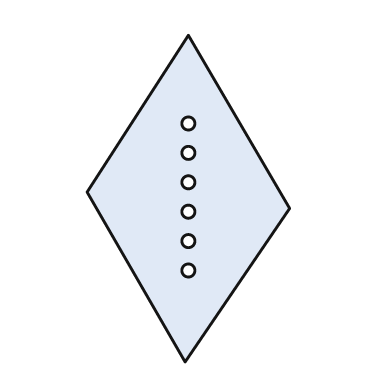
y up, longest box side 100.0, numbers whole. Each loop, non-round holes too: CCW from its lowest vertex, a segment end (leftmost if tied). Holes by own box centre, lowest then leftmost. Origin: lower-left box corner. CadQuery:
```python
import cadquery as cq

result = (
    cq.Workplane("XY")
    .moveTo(30.0, 0.0)
    .lineTo(62.0, 47.0)
    .lineTo(31.0, 100.0)
    .lineTo(0.0, 52.0)
    .close()
    .moveTo(31.0, 28.0)
    .circle(2.0)
    .moveTo(31.0, 37.0)
    .circle(2.0)
    .moveTo(31.0, 46.0)
    .circle(2.0)
    .moveTo(31.0, 55.0)
    .circle(2.0)
    .moveTo(31.0, 64.0)
    .circle(2.0)
    .moveTo(31.0, 73.0)
    .circle(2.0)
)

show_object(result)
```